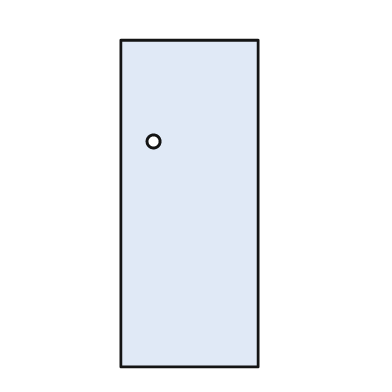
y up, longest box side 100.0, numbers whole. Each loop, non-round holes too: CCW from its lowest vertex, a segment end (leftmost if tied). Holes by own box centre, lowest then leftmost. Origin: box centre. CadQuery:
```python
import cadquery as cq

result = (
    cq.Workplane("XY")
    .moveTo(-21.0, -50.0)
    .lineTo(21.0, -50.0)
    .lineTo(21.0, 50.0)
    .lineTo(-21.0, 50.0)
    .close()
    .moveTo(-11.0, 19.0)
    .circle(2.0)
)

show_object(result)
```